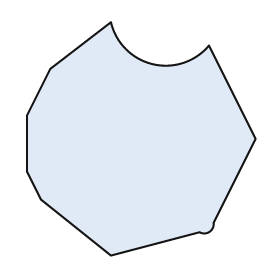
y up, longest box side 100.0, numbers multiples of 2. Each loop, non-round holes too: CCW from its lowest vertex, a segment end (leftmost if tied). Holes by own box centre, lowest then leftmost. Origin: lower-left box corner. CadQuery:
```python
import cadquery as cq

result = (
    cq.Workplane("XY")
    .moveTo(36.0, 0.0)
    .lineTo(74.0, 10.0)
    .threePointArc((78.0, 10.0), (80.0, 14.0))
    .lineTo(98.0, 50.0)
    .lineTo(78.0, 90.0)
    .threePointArc((54.0, 82.0), (36.0, 100.0))
    .lineTo(10.0, 80.0)
    .lineTo(0.0, 60.0)
    .lineTo(0.0, 36.0)
    .lineTo(6.0, 24.0)
    .close()
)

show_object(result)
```